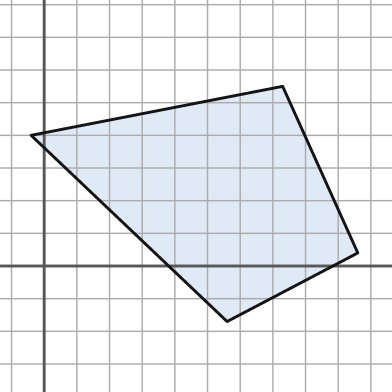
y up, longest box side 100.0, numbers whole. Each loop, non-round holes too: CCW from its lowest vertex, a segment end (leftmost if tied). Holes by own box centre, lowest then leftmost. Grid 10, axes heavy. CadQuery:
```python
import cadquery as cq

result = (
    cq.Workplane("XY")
    .moveTo(56.0, -17.0)
    .lineTo(96.0, 4.0)
    .lineTo(73.0, 55.0)
    .lineTo(-4.0, 40.0)
    .close()
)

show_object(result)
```